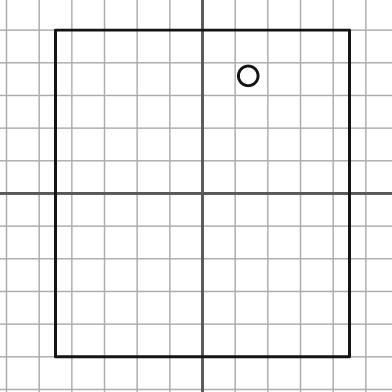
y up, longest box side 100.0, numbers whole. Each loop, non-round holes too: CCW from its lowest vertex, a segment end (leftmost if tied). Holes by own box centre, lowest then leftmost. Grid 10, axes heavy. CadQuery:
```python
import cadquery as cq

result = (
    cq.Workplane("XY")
    .moveTo(-45.0, -50.0)
    .lineTo(45.0, -50.0)
    .lineTo(45.0, 50.0)
    .lineTo(-45.0, 50.0)
    .close()
    .moveTo(14.0, 36.0)
    .circle(3.0)
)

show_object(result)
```